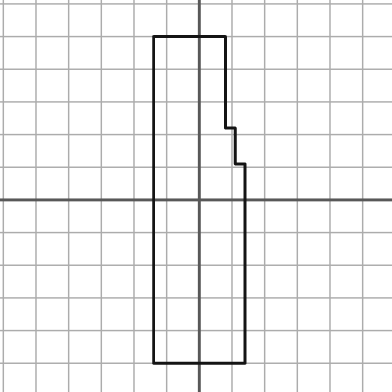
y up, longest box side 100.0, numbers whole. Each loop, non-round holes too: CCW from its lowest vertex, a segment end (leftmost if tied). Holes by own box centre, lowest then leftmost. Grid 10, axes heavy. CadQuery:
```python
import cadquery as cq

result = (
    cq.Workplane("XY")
    .moveTo(-14.0, -50.0)
    .lineTo(14.0, -50.0)
    .lineTo(14.0, 11.0)
    .lineTo(11.0, 11.0)
    .lineTo(11.0, 22.0)
    .lineTo(8.0, 22.0)
    .lineTo(8.0, 50.0)
    .lineTo(-14.0, 50.0)
    .close()
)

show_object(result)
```